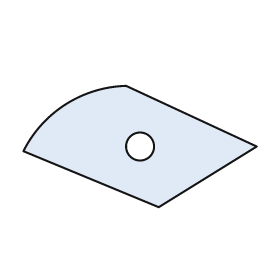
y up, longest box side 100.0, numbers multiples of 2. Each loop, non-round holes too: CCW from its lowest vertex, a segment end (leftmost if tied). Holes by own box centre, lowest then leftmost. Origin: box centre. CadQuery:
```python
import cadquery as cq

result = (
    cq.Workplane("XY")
    .moveTo(8.0, -26.0)
    .lineTo(50.0, 0.0)
    .lineTo(-6.0, 26.0)
    .threePointArc((-32.0, 18.0), (-50.0, -2.0))
    .close()
    .moveTo(0.0, 0.0)
    .circle(6.0)
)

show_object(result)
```